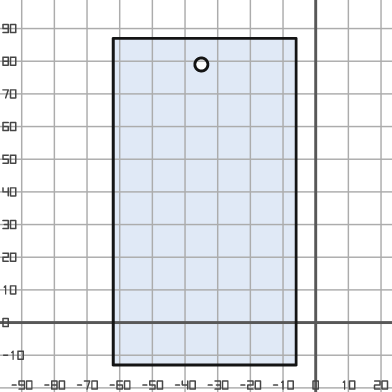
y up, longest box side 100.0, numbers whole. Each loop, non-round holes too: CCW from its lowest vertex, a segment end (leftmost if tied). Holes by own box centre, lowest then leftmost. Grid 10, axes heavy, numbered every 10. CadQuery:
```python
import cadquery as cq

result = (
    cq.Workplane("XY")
    .moveTo(-62.0, -13.0)
    .lineTo(-6.0, -13.0)
    .lineTo(-6.0, 87.0)
    .lineTo(-62.0, 87.0)
    .close()
    .moveTo(-35.0, 79.0)
    .circle(2.0)
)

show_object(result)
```